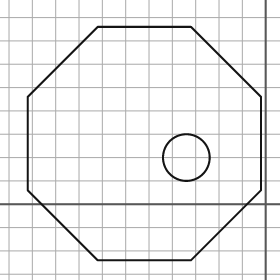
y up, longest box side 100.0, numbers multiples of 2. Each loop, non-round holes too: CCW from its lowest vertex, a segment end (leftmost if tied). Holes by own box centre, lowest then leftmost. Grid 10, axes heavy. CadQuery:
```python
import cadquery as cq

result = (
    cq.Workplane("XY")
    .moveTo(-72.0, -24.0)
    .lineTo(-32.0, -24.0)
    .lineTo(-2.0, 6.0)
    .lineTo(-2.0, 46.0)
    .lineTo(-32.0, 76.0)
    .lineTo(-72.0, 76.0)
    .lineTo(-102.0, 46.0)
    .lineTo(-102.0, 6.0)
    .close()
    .moveTo(-34.0, 20.0)
    .circle(10.0)
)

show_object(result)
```